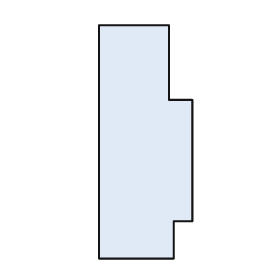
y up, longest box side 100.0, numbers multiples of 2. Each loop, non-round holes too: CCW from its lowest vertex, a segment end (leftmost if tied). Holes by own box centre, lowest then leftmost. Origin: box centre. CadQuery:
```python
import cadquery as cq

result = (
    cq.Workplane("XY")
    .moveTo(-20.0, -50.0)
    .lineTo(12.0, -50.0)
    .lineTo(12.0, -34.0)
    .lineTo(20.0, -34.0)
    .lineTo(20.0, 18.0)
    .lineTo(10.0, 18.0)
    .lineTo(10.0, 50.0)
    .lineTo(-20.0, 50.0)
    .close()
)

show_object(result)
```